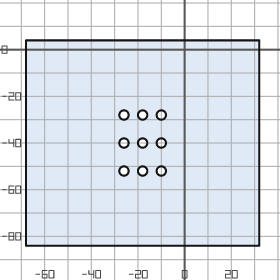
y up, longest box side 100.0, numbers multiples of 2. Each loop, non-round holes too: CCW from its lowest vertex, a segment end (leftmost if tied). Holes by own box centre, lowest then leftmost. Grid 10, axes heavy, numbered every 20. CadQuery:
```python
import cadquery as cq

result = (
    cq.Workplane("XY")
    .moveTo(-68.0, -84.0)
    .lineTo(32.0, -84.0)
    .lineTo(32.0, 4.0)
    .lineTo(-68.0, 4.0)
    .close()
    .moveTo(-26.0, -52.0)
    .circle(2.0)
    .moveTo(-18.0, -52.0)
    .circle(2.0)
    .moveTo(-10.0, -52.0)
    .circle(2.0)
    .moveTo(-26.0, -40.0)
    .circle(2.0)
    .moveTo(-18.0, -40.0)
    .circle(2.0)
    .moveTo(-10.0, -40.0)
    .circle(2.0)
    .moveTo(-26.0, -28.0)
    .circle(2.0)
    .moveTo(-18.0, -28.0)
    .circle(2.0)
    .moveTo(-10.0, -28.0)
    .circle(2.0)
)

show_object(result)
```